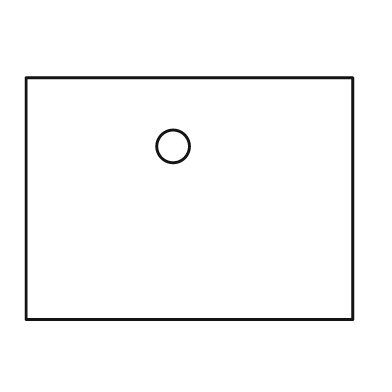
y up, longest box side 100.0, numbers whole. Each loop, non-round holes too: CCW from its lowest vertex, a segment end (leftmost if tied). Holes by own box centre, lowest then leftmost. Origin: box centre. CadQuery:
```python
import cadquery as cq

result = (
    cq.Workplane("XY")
    .moveTo(-50.0, -37.0)
    .lineTo(50.0, -37.0)
    .lineTo(50.0, 37.0)
    .lineTo(-50.0, 37.0)
    .close()
    .moveTo(-5.0, 16.0)
    .circle(5.0)
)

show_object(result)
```